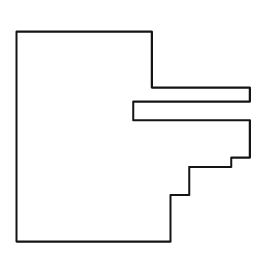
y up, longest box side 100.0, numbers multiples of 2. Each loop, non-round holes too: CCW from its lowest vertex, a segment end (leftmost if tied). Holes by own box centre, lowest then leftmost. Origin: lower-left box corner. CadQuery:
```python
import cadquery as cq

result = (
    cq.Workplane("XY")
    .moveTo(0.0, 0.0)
    .lineTo(66.0, 0.0)
    .lineTo(66.0, 20.0)
    .lineTo(74.0, 20.0)
    .lineTo(74.0, 32.0)
    .lineTo(92.0, 32.0)
    .lineTo(92.0, 36.0)
    .lineTo(100.0, 36.0)
    .lineTo(100.0, 52.0)
    .lineTo(50.0, 52.0)
    .lineTo(50.0, 60.0)
    .lineTo(100.0, 60.0)
    .lineTo(100.0, 66.0)
    .lineTo(58.0, 66.0)
    .lineTo(58.0, 90.0)
    .lineTo(0.0, 90.0)
    .close()
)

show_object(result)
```